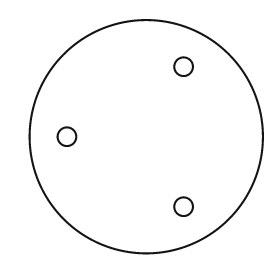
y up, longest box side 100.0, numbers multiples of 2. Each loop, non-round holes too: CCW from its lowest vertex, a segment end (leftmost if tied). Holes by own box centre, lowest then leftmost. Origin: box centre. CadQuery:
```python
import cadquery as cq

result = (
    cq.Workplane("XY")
    .moveTo(0.0, 0.0)
    .circle(50.0)
    .moveTo(16.0, -30.0)
    .circle(4.0)
    .moveTo(-34.0, 0.0)
    .circle(4.0)
    .moveTo(16.0, 30.0)
    .circle(4.0)
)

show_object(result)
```